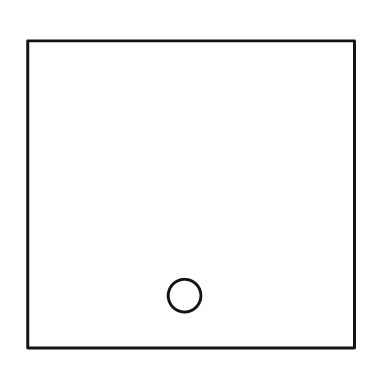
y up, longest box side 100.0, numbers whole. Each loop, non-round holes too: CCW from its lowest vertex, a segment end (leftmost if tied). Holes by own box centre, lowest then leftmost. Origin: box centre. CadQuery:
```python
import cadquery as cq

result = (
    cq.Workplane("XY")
    .moveTo(-50.0, -47.0)
    .lineTo(50.0, -47.0)
    .lineTo(50.0, 47.0)
    .lineTo(-50.0, 47.0)
    .close()
    .moveTo(-2.0, -31.0)
    .circle(5.0)
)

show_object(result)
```